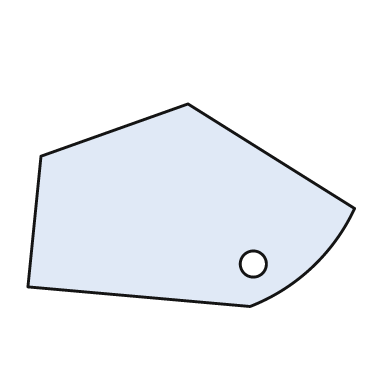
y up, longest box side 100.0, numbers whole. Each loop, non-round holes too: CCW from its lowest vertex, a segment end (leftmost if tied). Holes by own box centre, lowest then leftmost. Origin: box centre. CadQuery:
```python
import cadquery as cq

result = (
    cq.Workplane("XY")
    .moveTo(18.0, -31.0)
    .threePointArc((37.0, -19.0), (50.0, -1.0))
    .lineTo(-1.0, 31.0)
    .lineTo(-46.0, 15.0)
    .lineTo(-50.0, -25.0)
    .close()
    .moveTo(19.0, -18.0)
    .circle(4.0)
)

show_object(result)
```